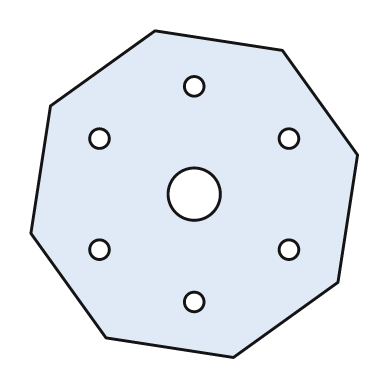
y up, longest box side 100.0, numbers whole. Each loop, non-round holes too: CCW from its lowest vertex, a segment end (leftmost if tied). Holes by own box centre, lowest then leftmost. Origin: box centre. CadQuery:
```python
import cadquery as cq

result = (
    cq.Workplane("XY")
    .moveTo(12.0, -50.0)
    .lineTo(44.0, -27.0)
    .lineTo(50.0, 12.0)
    .lineTo(27.0, 44.0)
    .lineTo(-12.0, 50.0)
    .lineTo(-44.0, 27.0)
    .lineTo(-50.0, -12.0)
    .lineTo(-27.0, -44.0)
    .close()
    .moveTo(0.0, -33.0)
    .circle(3.0)
    .moveTo(-29.0, -17.0)
    .circle(3.0)
    .moveTo(29.0, -17.0)
    .circle(3.0)
    .moveTo(0.0, 0.0)
    .circle(8.0)
    .moveTo(-29.0, 17.0)
    .circle(3.0)
    .moveTo(29.0, 17.0)
    .circle(3.0)
    .moveTo(0.0, 33.0)
    .circle(3.0)
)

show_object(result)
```